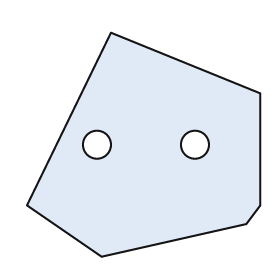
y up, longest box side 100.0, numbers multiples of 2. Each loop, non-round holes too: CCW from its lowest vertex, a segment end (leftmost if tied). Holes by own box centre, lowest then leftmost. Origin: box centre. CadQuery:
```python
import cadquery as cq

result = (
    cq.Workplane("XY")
    .moveTo(-18.0, -48.0)
    .lineTo(44.0, -34.0)
    .lineTo(50.0, -26.0)
    .lineTo(50.0, 22.0)
    .lineTo(-14.0, 48.0)
    .lineTo(-50.0, -26.0)
    .close()
    .moveTo(-20.0, 0.0)
    .circle(6.0)
    .moveTo(22.0, 0.0)
    .circle(6.0)
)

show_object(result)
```